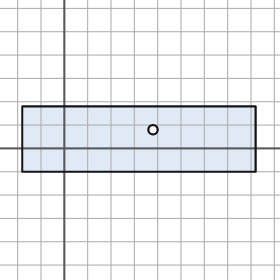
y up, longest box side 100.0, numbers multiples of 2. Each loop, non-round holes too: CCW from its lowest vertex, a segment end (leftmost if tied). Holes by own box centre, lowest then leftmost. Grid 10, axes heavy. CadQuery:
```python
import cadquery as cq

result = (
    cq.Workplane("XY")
    .moveTo(-18.0, -10.0)
    .lineTo(82.0, -10.0)
    .lineTo(82.0, 18.0)
    .lineTo(-18.0, 18.0)
    .close()
    .moveTo(38.0, 8.0)
    .circle(2.0)
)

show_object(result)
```